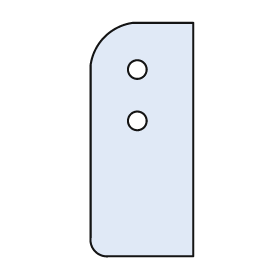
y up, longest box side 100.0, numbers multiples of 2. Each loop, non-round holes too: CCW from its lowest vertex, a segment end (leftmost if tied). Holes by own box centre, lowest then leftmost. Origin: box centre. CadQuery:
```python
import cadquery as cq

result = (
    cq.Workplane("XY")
    .moveTo(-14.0, -50.0)
    .lineTo(22.0, -50.0)
    .lineTo(22.0, 50.0)
    .lineTo(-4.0, 50.0)
    .threePointArc((-16.0, 44.0), (-22.0, 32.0))
    .lineTo(-22.0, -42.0)
    .threePointArc((-20.0, -48.0), (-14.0, -50.0))
    .close()
    .moveTo(-2.0, 8.0)
    .circle(4.0)
    .moveTo(-2.0, 30.0)
    .circle(4.0)
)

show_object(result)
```